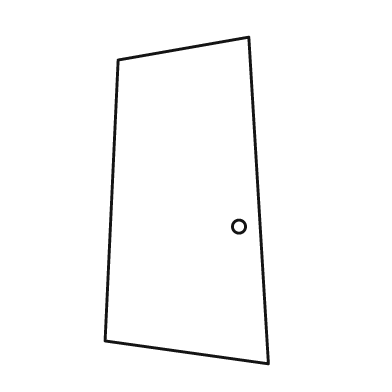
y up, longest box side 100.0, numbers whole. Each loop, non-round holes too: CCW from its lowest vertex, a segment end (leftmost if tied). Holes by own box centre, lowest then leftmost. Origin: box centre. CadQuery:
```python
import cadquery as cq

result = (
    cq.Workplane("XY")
    .moveTo(25.0, -50.0)
    .lineTo(19.0, 50.0)
    .lineTo(-21.0, 43.0)
    .lineTo(-25.0, -43.0)
    .close()
    .moveTo(16.0, -8.0)
    .circle(2.0)
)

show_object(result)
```